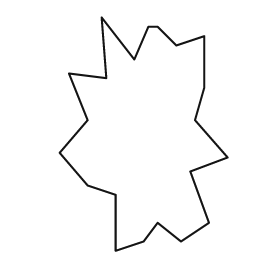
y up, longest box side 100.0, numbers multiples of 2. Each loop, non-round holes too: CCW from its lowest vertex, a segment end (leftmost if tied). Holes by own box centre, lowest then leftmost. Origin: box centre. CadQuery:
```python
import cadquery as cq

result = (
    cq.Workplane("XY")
    .moveTo(-12.0, -50.0)
    .lineTo(0.0, -46.0)
    .lineTo(6.0, -38.0)
    .lineTo(16.0, -46.0)
    .lineTo(28.0, -38.0)
    .lineTo(20.0, -16.0)
    .lineTo(36.0, -10.0)
    .lineTo(22.0, 6.0)
    .lineTo(26.0, 20.0)
    .lineTo(26.0, 42.0)
    .lineTo(14.0, 38.0)
    .lineTo(6.0, 46.0)
    .lineTo(2.0, 46.0)
    .lineTo(-4.0, 32.0)
    .lineTo(-18.0, 50.0)
    .lineTo(-16.0, 24.0)
    .lineTo(-32.0, 26.0)
    .lineTo(-24.0, 6.0)
    .lineTo(-36.0, -8.0)
    .lineTo(-24.0, -22.0)
    .lineTo(-12.0, -26.0)
    .close()
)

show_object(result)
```